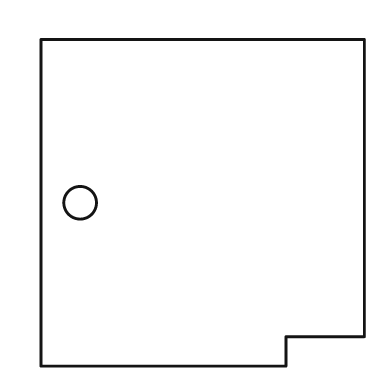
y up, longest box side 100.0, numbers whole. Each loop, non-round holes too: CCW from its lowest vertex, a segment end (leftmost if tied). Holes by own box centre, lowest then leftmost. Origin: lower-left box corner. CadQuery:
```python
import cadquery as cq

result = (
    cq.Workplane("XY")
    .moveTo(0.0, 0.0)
    .lineTo(75.0, 0.0)
    .lineTo(75.0, 9.0)
    .lineTo(99.0, 9.0)
    .lineTo(99.0, 100.0)
    .lineTo(0.0, 100.0)
    .close()
    .moveTo(12.0, 50.0)
    .circle(5.0)
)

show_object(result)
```